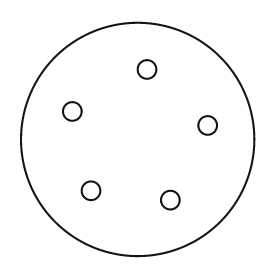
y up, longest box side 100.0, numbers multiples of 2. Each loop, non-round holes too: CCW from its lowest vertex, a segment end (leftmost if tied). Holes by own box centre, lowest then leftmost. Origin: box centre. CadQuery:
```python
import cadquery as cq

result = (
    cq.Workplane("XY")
    .moveTo(0.0, 0.0)
    .circle(50.0)
    .moveTo(14.0, -26.0)
    .circle(4.0)
    .moveTo(-20.0, -22.0)
    .circle(4.0)
    .moveTo(30.0, 6.0)
    .circle(4.0)
    .moveTo(-28.0, 12.0)
    .circle(4.0)
    .moveTo(4.0, 30.0)
    .circle(4.0)
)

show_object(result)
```